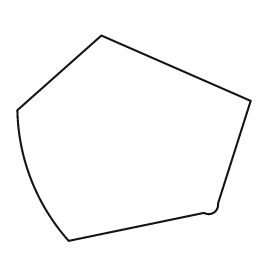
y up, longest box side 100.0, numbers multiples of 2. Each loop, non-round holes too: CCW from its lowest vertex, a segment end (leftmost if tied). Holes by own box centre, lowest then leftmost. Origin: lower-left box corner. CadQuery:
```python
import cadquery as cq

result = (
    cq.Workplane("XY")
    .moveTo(22.0, 0.0)
    .lineTo(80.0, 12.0)
    .threePointArc((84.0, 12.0), (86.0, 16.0))
    .lineTo(100.0, 60.0)
    .lineTo(36.0, 88.0)
    .lineTo(0.0, 56.0)
    .threePointArc((6.0, 26.0), (22.0, 0.0))
    .close()
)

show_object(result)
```